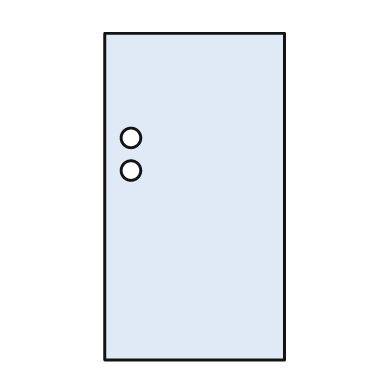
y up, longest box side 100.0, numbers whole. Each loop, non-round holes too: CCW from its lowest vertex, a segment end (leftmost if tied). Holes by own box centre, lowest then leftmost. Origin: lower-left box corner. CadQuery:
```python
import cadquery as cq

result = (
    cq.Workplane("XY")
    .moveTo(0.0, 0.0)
    .lineTo(55.0, 0.0)
    .lineTo(55.0, 100.0)
    .lineTo(0.0, 100.0)
    .close()
    .moveTo(8.0, 58.0)
    .circle(3.0)
    .moveTo(8.0, 68.0)
    .circle(3.0)
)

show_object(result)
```